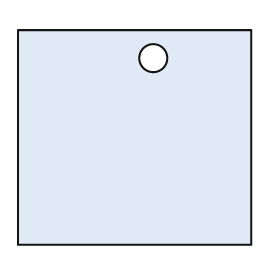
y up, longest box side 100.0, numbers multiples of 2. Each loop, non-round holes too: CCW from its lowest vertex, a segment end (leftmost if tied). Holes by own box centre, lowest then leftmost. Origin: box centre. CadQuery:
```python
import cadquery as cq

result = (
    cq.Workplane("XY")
    .moveTo(-50.0, -46.0)
    .lineTo(50.0, -46.0)
    .lineTo(50.0, 46.0)
    .lineTo(-50.0, 46.0)
    .close()
    .moveTo(8.0, 34.0)
    .circle(6.0)
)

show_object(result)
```